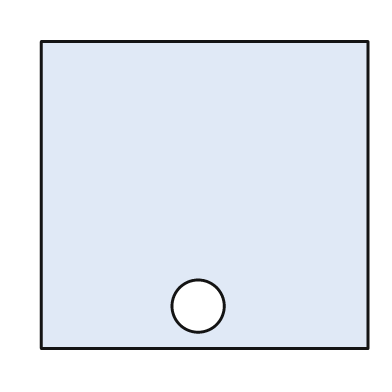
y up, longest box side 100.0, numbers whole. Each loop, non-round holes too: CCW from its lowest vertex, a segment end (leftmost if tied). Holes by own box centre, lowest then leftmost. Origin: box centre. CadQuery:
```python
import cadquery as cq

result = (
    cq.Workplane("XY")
    .moveTo(-50.0, -47.0)
    .lineTo(50.0, -47.0)
    .lineTo(50.0, 47.0)
    .lineTo(-50.0, 47.0)
    .close()
    .moveTo(-2.0, -34.0)
    .circle(8.0)
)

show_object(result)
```